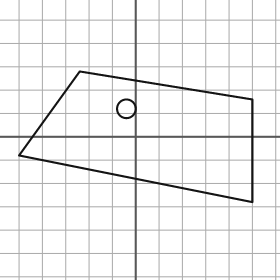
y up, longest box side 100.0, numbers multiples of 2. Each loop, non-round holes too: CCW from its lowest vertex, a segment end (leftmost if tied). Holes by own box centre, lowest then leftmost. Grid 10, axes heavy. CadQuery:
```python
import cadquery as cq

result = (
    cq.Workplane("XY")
    .moveTo(50.0, -28.0)
    .lineTo(50.0, 16.0)
    .lineTo(-24.0, 28.0)
    .lineTo(-50.0, -8.0)
    .close()
    .moveTo(-4.0, 12.0)
    .circle(4.0)
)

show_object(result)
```